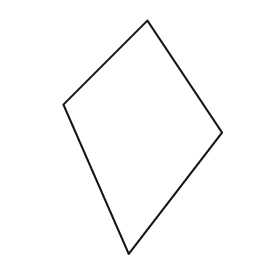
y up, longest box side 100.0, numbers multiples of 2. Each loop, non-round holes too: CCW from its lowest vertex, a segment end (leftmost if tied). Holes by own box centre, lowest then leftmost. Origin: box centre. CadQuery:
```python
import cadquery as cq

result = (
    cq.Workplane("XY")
    .moveTo(-6.0, -50.0)
    .lineTo(34.0, 2.0)
    .lineTo(2.0, 50.0)
    .lineTo(-34.0, 14.0)
    .close()
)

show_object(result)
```